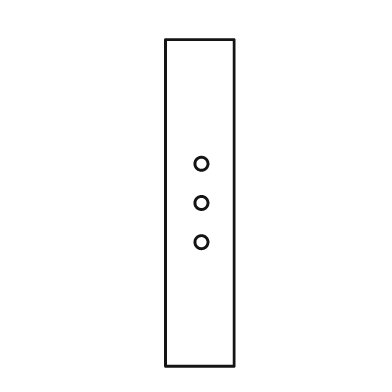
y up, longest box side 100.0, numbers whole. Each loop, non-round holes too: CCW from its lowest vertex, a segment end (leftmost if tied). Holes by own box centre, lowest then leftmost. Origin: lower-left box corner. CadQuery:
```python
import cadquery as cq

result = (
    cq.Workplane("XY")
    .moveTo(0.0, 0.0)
    .lineTo(21.0, 0.0)
    .lineTo(21.0, 100.0)
    .lineTo(0.0, 100.0)
    .close()
    .moveTo(11.0, 38.0)
    .circle(2.0)
    .moveTo(11.0, 50.0)
    .circle(2.0)
    .moveTo(11.0, 62.0)
    .circle(2.0)
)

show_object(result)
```